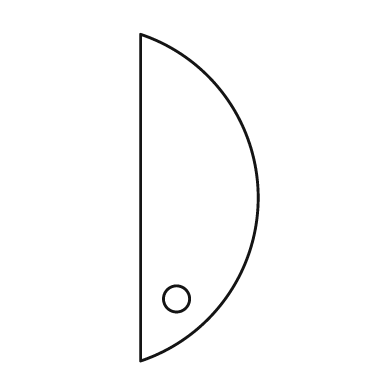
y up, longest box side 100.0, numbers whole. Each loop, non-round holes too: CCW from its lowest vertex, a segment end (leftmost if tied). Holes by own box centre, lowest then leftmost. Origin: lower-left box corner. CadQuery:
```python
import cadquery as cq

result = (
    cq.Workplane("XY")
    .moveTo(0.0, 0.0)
    .threePointArc((36.0, 50.0), (0.0, 100.0))
    .close()
    .moveTo(11.0, 19.0)
    .circle(4.0)
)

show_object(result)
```